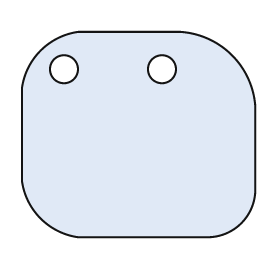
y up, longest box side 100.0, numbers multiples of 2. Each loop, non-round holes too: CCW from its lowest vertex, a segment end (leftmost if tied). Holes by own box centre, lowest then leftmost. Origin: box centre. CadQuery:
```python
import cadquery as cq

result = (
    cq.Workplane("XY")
    .moveTo(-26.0, -44.0)
    .lineTo(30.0, -44.0)
    .threePointArc((44.0, -38.0), (50.0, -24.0))
    .lineTo(50.0, 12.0)
    .threePointArc((40.0, 34.0), (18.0, 44.0))
    .lineTo(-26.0, 44.0)
    .threePointArc((-42.0, 36.0), (-50.0, 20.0))
    .lineTo(-50.0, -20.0)
    .threePointArc((-42.0, -36.0), (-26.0, -44.0))
    .close()
    .moveTo(-32.0, 28.0)
    .circle(6.0)
    .moveTo(10.0, 28.0)
    .circle(6.0)
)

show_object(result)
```